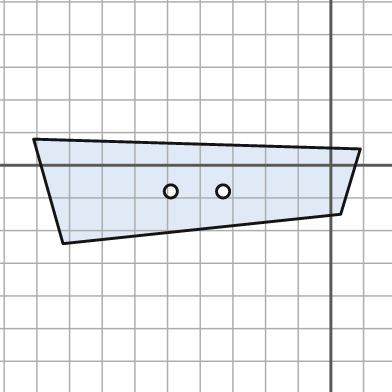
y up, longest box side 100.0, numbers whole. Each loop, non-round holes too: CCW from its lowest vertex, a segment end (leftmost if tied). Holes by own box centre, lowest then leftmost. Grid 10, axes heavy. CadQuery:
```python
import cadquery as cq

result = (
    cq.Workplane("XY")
    .moveTo(-82.0, -24.0)
    .lineTo(3.0, -15.0)
    .lineTo(9.0, 5.0)
    .lineTo(-91.0, 8.0)
    .close()
    .moveTo(-49.0, -8.0)
    .circle(2.0)
    .moveTo(-33.0, -8.0)
    .circle(2.0)
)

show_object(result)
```